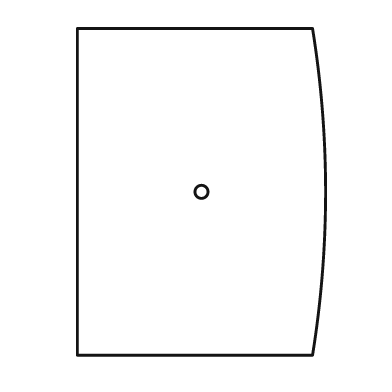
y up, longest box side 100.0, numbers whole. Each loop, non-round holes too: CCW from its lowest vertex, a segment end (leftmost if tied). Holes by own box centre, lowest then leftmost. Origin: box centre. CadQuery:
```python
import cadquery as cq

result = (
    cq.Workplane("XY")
    .moveTo(-38.0, -50.0)
    .lineTo(34.0, -50.0)
    .threePointArc((38.0, 0.0), (34.0, 50.0))
    .lineTo(-38.0, 50.0)
    .close()
    .moveTo(0.0, 0.0)
    .circle(2.0)
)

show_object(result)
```